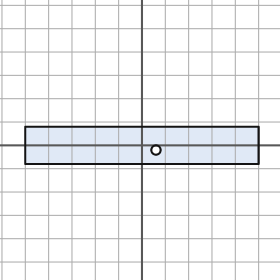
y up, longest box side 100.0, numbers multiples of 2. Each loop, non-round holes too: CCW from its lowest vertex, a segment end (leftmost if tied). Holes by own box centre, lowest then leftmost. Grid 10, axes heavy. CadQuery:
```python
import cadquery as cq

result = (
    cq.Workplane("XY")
    .moveTo(-50.0, -8.0)
    .lineTo(50.0, -8.0)
    .lineTo(50.0, 8.0)
    .lineTo(-50.0, 8.0)
    .close()
    .moveTo(6.0, -2.0)
    .circle(2.0)
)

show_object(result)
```